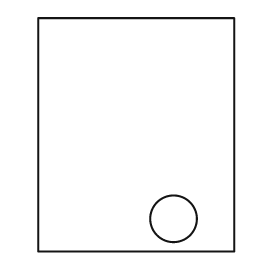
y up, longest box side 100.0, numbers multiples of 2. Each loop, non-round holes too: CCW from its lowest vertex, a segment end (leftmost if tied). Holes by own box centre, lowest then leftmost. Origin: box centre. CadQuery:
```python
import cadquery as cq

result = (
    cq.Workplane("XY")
    .moveTo(-42.0, -50.0)
    .lineTo(42.0, -50.0)
    .lineTo(42.0, 50.0)
    .lineTo(-42.0, 50.0)
    .close()
    .moveTo(16.0, -36.0)
    .circle(10.0)
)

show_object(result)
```